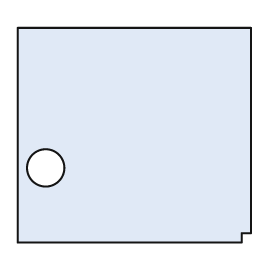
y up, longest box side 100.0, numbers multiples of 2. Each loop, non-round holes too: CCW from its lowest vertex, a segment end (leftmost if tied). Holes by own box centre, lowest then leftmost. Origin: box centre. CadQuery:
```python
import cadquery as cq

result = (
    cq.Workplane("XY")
    .moveTo(-50.0, -46.0)
    .lineTo(46.0, -46.0)
    .lineTo(46.0, -42.0)
    .lineTo(50.0, -42.0)
    .lineTo(50.0, 46.0)
    .lineTo(-50.0, 46.0)
    .close()
    .moveTo(-38.0, -14.0)
    .circle(8.0)
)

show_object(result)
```